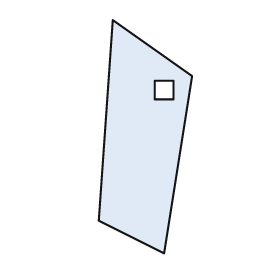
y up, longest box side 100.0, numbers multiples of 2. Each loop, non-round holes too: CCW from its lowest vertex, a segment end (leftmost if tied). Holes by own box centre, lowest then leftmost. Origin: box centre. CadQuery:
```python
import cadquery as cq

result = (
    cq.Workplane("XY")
    .moveTo(8.0, -50.0)
    .lineTo(20.0, 26.0)
    .lineTo(-14.0, 50.0)
    .lineTo(-20.0, -36.0)
    .close()
    .moveTo(4.0, 16.0)
    .lineTo(12.0, 16.0)
    .lineTo(12.0, 24.0)
    .lineTo(4.0, 24.0)
    .close()
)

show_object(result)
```